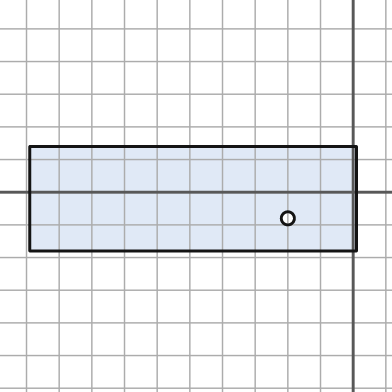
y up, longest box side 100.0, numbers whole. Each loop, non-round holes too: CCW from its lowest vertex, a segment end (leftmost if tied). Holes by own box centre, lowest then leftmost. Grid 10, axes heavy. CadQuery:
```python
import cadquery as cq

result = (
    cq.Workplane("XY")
    .moveTo(-99.0, -18.0)
    .lineTo(1.0, -18.0)
    .lineTo(1.0, 14.0)
    .lineTo(-99.0, 14.0)
    .close()
    .moveTo(-20.0, -8.0)
    .circle(2.0)
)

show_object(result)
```